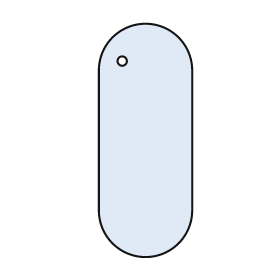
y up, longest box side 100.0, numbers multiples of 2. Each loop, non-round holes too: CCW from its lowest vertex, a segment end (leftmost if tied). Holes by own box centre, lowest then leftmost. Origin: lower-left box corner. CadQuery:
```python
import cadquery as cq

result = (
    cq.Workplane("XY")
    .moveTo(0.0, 20.0)
    .threePointArc((20.0, 0.0), (40.0, 20.0))
    .lineTo(40.0, 80.0)
    .threePointArc((20.0, 100.0), (0.0, 80.0))
    .close()
    .moveTo(10.0, 84.0)
    .circle(2.0)
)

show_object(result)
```